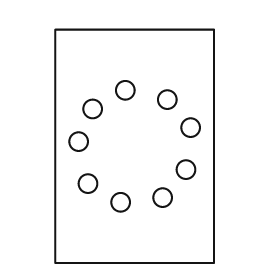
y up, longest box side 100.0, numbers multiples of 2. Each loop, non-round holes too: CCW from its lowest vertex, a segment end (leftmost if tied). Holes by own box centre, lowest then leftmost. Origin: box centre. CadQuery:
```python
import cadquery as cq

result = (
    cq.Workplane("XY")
    .moveTo(-34.0, -50.0)
    .lineTo(34.0, -50.0)
    .lineTo(34.0, 50.0)
    .lineTo(-34.0, 50.0)
    .close()
    .moveTo(-6.0, -24.0)
    .circle(4.0)
    .moveTo(12.0, -22.0)
    .circle(4.0)
    .moveTo(-20.0, -16.0)
    .circle(4.0)
    .moveTo(22.0, -10.0)
    .circle(4.0)
    .moveTo(-24.0, 2.0)
    .circle(4.0)
    .moveTo(24.0, 8.0)
    .circle(4.0)
    .moveTo(-18.0, 16.0)
    .circle(4.0)
    .moveTo(14.0, 20.0)
    .circle(4.0)
    .moveTo(-4.0, 24.0)
    .circle(4.0)
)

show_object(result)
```